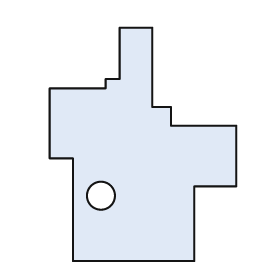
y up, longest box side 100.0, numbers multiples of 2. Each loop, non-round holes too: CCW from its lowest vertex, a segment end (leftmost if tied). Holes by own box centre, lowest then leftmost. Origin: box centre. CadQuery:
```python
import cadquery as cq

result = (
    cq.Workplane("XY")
    .moveTo(-30.0, -50.0)
    .lineTo(22.0, -50.0)
    .lineTo(22.0, -18.0)
    .lineTo(40.0, -18.0)
    .lineTo(40.0, 8.0)
    .lineTo(12.0, 8.0)
    .lineTo(12.0, 16.0)
    .lineTo(4.0, 16.0)
    .lineTo(4.0, 50.0)
    .lineTo(-10.0, 50.0)
    .lineTo(-10.0, 28.0)
    .lineTo(-16.0, 28.0)
    .lineTo(-16.0, 24.0)
    .lineTo(-40.0, 24.0)
    .lineTo(-40.0, -6.0)
    .lineTo(-30.0, -6.0)
    .close()
    .moveTo(-18.0, -22.0)
    .circle(6.0)
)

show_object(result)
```